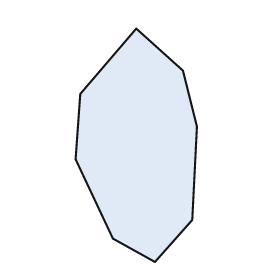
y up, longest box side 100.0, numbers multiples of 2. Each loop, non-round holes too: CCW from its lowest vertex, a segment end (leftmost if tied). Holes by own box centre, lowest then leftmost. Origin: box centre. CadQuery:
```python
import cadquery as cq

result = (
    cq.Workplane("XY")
    .moveTo(8.0, -50.0)
    .lineTo(24.0, -32.0)
    .lineTo(26.0, 8.0)
    .lineTo(20.0, 32.0)
    .lineTo(0.0, 50.0)
    .lineTo(-24.0, 22.0)
    .lineTo(-26.0, -6.0)
    .lineTo(-10.0, -40.0)
    .close()
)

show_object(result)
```